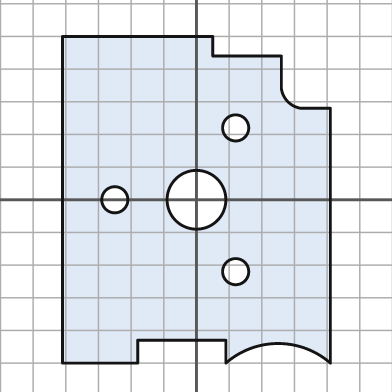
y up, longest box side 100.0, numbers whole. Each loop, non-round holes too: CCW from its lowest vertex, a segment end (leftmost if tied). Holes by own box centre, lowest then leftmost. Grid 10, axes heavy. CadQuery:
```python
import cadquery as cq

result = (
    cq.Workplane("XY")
    .moveTo(-41.0, -50.0)
    .lineTo(-18.0, -50.0)
    .lineTo(-18.0, -43.0)
    .lineTo(9.0, -43.0)
    .lineTo(9.0, -50.0)
    .threePointArc((25.0, -44.0), (41.0, -50.0))
    .lineTo(41.0, 28.0)
    .lineTo(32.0, 28.0)
    .threePointArc((28.0, 30.0), (26.0, 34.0))
    .lineTo(26.0, 44.0)
    .lineTo(5.0, 44.0)
    .lineTo(5.0, 50.0)
    .lineTo(-41.0, 50.0)
    .close()
    .moveTo(12.0, -22.0)
    .circle(4.0)
    .moveTo(-25.0, 0.0)
    .circle(4.0)
    .moveTo(0.0, 0.0)
    .circle(9.0)
    .moveTo(12.0, 22.0)
    .circle(4.0)
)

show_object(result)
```